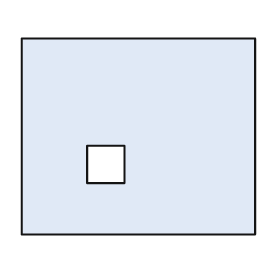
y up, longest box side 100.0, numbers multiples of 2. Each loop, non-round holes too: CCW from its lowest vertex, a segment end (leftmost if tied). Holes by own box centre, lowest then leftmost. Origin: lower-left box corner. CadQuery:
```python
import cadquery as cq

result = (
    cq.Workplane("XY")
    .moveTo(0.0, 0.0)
    .lineTo(100.0, 0.0)
    .lineTo(100.0, 84.0)
    .lineTo(0.0, 84.0)
    .close()
    .moveTo(28.0, 22.0)
    .lineTo(44.0, 22.0)
    .lineTo(44.0, 38.0)
    .lineTo(28.0, 38.0)
    .close()
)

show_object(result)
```